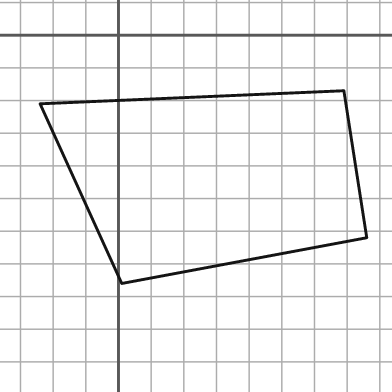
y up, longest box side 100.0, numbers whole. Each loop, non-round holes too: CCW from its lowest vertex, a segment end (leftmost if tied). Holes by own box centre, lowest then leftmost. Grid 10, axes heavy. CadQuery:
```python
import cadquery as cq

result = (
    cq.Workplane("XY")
    .moveTo(1.0, -76.0)
    .lineTo(76.0, -62.0)
    .lineTo(69.0, -17.0)
    .lineTo(-24.0, -21.0)
    .close()
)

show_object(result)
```